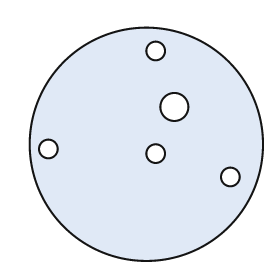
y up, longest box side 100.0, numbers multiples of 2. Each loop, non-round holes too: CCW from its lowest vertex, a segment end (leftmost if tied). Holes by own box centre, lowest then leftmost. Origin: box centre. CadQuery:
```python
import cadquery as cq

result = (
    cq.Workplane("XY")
    .moveTo(0.0, 0.0)
    .circle(50.0)
    .moveTo(36.0, -14.0)
    .circle(4.0)
    .moveTo(4.0, -4.0)
    .circle(4.0)
    .moveTo(-42.0, -2.0)
    .circle(4.0)
    .moveTo(12.0, 16.0)
    .circle(6.0)
    .moveTo(4.0, 40.0)
    .circle(4.0)
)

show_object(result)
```